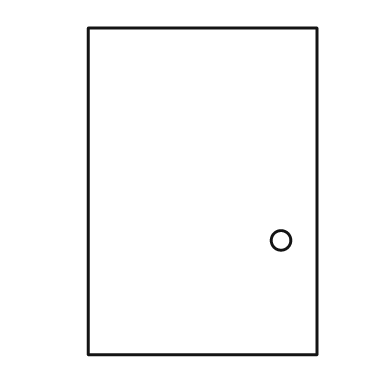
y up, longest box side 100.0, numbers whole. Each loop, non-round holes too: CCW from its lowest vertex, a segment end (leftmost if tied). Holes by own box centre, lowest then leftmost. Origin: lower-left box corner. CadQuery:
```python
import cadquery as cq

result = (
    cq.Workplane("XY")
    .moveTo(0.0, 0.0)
    .lineTo(70.0, 0.0)
    .lineTo(70.0, 100.0)
    .lineTo(0.0, 100.0)
    .close()
    .moveTo(59.0, 35.0)
    .circle(3.0)
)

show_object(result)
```